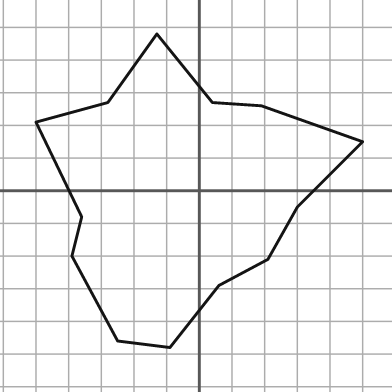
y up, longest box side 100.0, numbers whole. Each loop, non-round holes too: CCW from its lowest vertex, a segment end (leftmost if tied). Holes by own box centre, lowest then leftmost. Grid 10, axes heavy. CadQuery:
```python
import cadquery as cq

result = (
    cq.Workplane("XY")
    .moveTo(-9.0, -48.0)
    .lineTo(6.0, -29.0)
    .lineTo(21.0, -21.0)
    .lineTo(30.0, -5.0)
    .lineTo(50.0, 15.0)
    .lineTo(19.0, 26.0)
    .lineTo(4.0, 27.0)
    .lineTo(-13.0, 48.0)
    .lineTo(-28.0, 27.0)
    .lineTo(-50.0, 21.0)
    .lineTo(-36.0, -8.0)
    .lineTo(-39.0, -20.0)
    .lineTo(-25.0, -46.0)
    .close()
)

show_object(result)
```